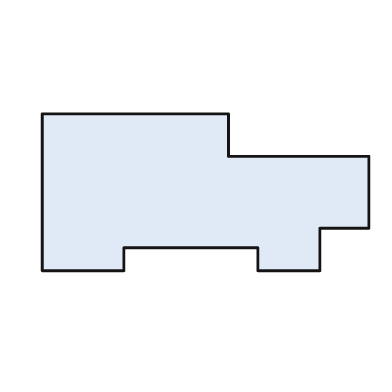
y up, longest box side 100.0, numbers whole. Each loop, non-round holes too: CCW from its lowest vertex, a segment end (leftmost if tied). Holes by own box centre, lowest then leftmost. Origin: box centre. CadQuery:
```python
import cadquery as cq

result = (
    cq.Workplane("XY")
    .moveTo(-50.0, -24.0)
    .lineTo(-25.0, -24.0)
    .lineTo(-25.0, -17.0)
    .lineTo(16.0, -17.0)
    .lineTo(16.0, -24.0)
    .lineTo(35.0, -24.0)
    .lineTo(35.0, -11.0)
    .lineTo(50.0, -11.0)
    .lineTo(50.0, 11.0)
    .lineTo(7.0, 11.0)
    .lineTo(7.0, 24.0)
    .lineTo(-50.0, 24.0)
    .close()
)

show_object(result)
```